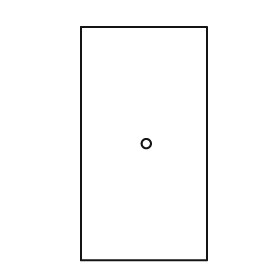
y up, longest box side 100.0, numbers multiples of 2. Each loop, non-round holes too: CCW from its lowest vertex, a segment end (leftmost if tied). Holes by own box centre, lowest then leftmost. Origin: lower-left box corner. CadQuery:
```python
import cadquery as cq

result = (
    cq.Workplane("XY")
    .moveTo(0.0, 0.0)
    .lineTo(54.0, 0.0)
    .lineTo(54.0, 100.0)
    .lineTo(0.0, 100.0)
    .close()
    .moveTo(28.0, 50.0)
    .circle(2.0)
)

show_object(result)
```